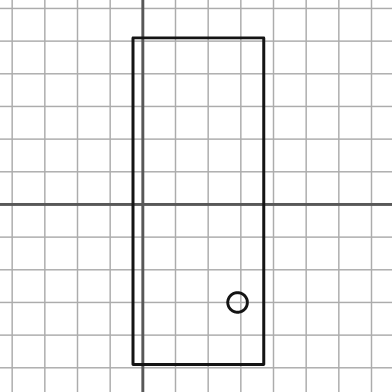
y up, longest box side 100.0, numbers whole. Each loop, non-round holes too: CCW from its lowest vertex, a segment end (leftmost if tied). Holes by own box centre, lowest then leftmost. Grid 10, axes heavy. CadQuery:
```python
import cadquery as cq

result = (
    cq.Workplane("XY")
    .moveTo(-3.0, -49.0)
    .lineTo(37.0, -49.0)
    .lineTo(37.0, 51.0)
    .lineTo(-3.0, 51.0)
    .close()
    .moveTo(29.0, -30.0)
    .circle(3.0)
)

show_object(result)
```